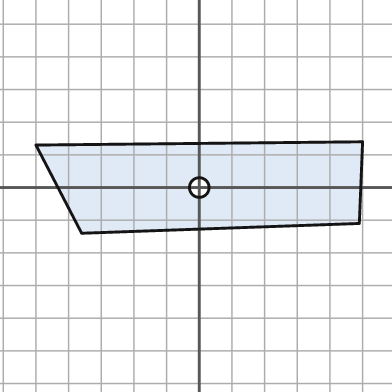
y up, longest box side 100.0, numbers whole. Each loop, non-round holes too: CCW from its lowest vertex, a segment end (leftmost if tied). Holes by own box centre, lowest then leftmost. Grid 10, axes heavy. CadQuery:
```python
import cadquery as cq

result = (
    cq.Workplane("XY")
    .moveTo(-36.0, -14.0)
    .lineTo(49.0, -11.0)
    .lineTo(50.0, 14.0)
    .lineTo(-50.0, 13.0)
    .close()
    .moveTo(0.0, 0.0)
    .circle(3.0)
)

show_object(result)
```